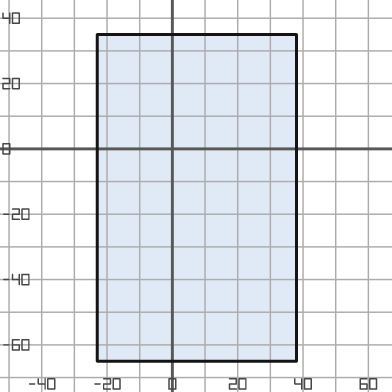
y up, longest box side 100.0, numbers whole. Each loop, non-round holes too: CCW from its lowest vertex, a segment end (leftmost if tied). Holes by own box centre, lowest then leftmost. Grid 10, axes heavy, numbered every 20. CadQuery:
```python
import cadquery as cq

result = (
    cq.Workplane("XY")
    .moveTo(-23.0, -65.0)
    .lineTo(38.0, -65.0)
    .lineTo(38.0, 35.0)
    .lineTo(-23.0, 35.0)
    .close()
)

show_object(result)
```